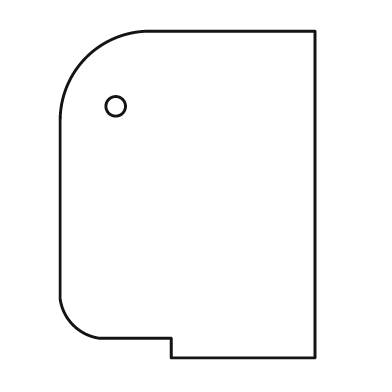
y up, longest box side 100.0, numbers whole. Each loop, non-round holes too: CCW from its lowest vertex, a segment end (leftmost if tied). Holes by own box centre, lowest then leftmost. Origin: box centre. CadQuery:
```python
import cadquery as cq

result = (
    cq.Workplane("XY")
    .moveTo(-5.0, -50.0)
    .lineTo(39.0, -50.0)
    .lineTo(39.0, 50.0)
    .lineTo(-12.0, 50.0)
    .threePointArc((-31.0, 42.0), (-39.0, 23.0))
    .lineTo(-39.0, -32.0)
    .threePointArc((-35.0, -40.0), (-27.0, -44.0))
    .lineTo(-5.0, -44.0)
    .close()
    .moveTo(-22.0, 27.0)
    .circle(3.0)
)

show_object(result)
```